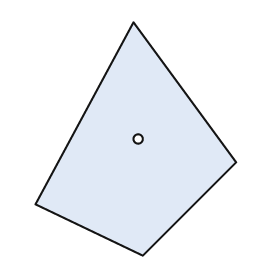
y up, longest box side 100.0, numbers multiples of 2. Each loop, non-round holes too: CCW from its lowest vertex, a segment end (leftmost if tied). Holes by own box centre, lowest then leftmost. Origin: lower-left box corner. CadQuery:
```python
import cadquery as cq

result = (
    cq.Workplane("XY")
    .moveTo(46.0, 0.0)
    .lineTo(86.0, 40.0)
    .lineTo(42.0, 100.0)
    .lineTo(0.0, 22.0)
    .close()
    .moveTo(44.0, 50.0)
    .circle(2.0)
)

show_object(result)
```